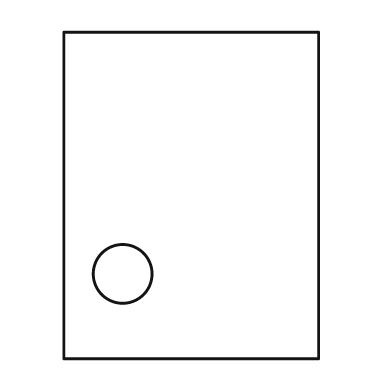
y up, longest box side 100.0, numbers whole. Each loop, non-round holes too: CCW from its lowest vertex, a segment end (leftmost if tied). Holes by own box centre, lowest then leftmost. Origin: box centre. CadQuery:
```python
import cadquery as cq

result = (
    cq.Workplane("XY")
    .moveTo(-39.0, -50.0)
    .lineTo(39.0, -50.0)
    .lineTo(39.0, 50.0)
    .lineTo(-39.0, 50.0)
    .close()
    .moveTo(-21.0, -24.0)
    .circle(9.0)
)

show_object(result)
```